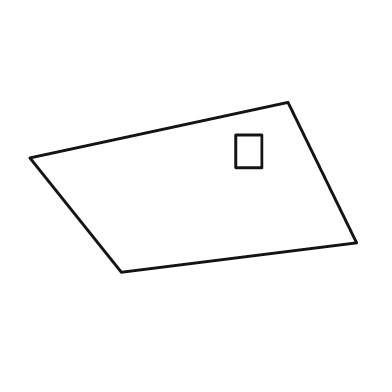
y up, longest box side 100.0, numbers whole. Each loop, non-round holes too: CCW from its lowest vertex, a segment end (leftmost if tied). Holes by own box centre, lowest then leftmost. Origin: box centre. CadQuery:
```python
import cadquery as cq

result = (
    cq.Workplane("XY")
    .moveTo(-22.0, -26.0)
    .lineTo(50.0, -17.0)
    .lineTo(29.0, 26.0)
    .lineTo(-50.0, 9.0)
    .close()
    .moveTo(13.0, 6.0)
    .lineTo(21.0, 6.0)
    .lineTo(21.0, 16.0)
    .lineTo(13.0, 16.0)
    .close()
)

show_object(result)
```